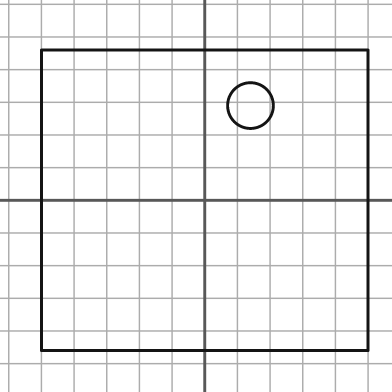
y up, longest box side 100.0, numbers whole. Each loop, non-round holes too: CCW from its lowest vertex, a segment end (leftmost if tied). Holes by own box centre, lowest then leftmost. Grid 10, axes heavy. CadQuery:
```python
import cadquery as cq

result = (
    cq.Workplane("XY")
    .moveTo(-50.0, -46.0)
    .lineTo(50.0, -46.0)
    .lineTo(50.0, 46.0)
    .lineTo(-50.0, 46.0)
    .close()
    .moveTo(14.0, 29.0)
    .circle(7.0)
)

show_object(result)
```